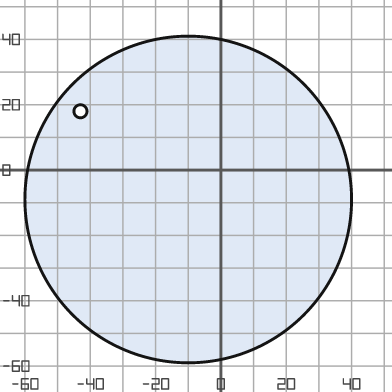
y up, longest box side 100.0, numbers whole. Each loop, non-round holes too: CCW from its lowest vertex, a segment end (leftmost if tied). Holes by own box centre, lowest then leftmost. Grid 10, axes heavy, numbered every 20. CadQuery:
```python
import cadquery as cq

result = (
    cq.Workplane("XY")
    .moveTo(-10.0, -9.0)
    .circle(50.0)
    .moveTo(-43.0, 18.0)
    .circle(2.0)
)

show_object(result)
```